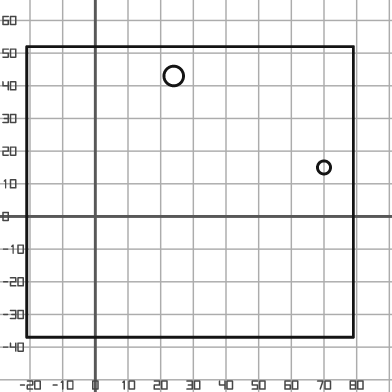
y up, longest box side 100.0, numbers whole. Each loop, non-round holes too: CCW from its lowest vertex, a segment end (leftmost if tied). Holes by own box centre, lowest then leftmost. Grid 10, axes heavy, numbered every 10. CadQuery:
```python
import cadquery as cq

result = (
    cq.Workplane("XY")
    .moveTo(-21.0, -37.0)
    .lineTo(79.0, -37.0)
    .lineTo(79.0, 52.0)
    .lineTo(-21.0, 52.0)
    .close()
    .moveTo(70.0, 15.0)
    .circle(2.0)
    .moveTo(24.0, 43.0)
    .circle(3.0)
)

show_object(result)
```